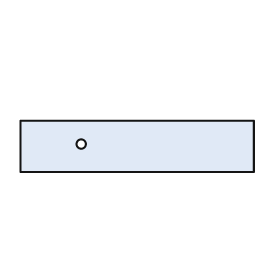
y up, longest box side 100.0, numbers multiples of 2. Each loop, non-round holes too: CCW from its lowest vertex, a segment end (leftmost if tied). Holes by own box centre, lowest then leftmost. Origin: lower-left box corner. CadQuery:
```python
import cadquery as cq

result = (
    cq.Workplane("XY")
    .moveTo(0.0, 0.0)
    .lineTo(100.0, 0.0)
    .lineTo(100.0, 22.0)
    .lineTo(0.0, 22.0)
    .close()
    .moveTo(26.0, 12.0)
    .circle(2.0)
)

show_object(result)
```